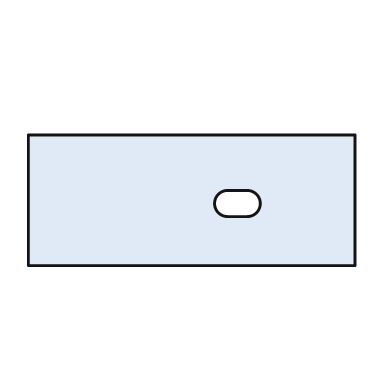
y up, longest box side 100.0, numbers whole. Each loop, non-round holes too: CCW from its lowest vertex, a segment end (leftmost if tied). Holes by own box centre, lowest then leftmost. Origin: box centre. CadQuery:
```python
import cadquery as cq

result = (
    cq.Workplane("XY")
    .moveTo(-50.0, -20.0)
    .lineTo(50.0, -20.0)
    .lineTo(50.0, 20.0)
    .lineTo(-50.0, 20.0)
    .close()
    .moveTo(11.0, -5.0)
    .lineTo(17.0, -5.0)
    .threePointArc((21.0, -1.0), (17.0, 3.0))
    .lineTo(11.0, 3.0)
    .threePointArc((7.0, -1.0), (11.0, -5.0))
    .close()
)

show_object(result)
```